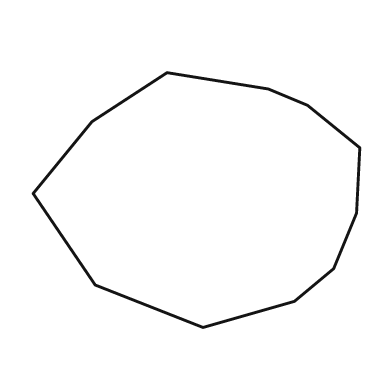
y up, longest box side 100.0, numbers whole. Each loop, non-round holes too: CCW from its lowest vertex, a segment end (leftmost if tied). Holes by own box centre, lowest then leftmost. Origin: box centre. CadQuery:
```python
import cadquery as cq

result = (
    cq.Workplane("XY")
    .moveTo(2.0, -39.0)
    .lineTo(30.0, -31.0)
    .lineTo(42.0, -21.0)
    .lineTo(49.0, -4.0)
    .lineTo(50.0, 16.0)
    .lineTo(34.0, 29.0)
    .lineTo(22.0, 34.0)
    .lineTo(-9.0, 39.0)
    .lineTo(-32.0, 24.0)
    .lineTo(-50.0, 2.0)
    .lineTo(-31.0, -26.0)
    .close()
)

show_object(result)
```